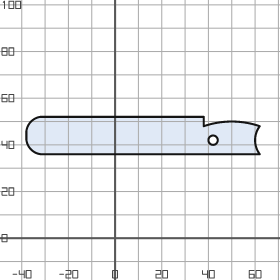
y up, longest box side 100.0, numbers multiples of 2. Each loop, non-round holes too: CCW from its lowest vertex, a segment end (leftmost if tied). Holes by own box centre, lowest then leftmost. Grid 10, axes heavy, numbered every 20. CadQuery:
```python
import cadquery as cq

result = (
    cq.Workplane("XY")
    .moveTo(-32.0, 36.0)
    .lineTo(62.0, 36.0)
    .threePointArc((60.0, 42.0), (62.0, 48.0))
    .threePointArc((50.0, 50.0), (38.0, 48.0))
    .lineTo(38.0, 52.0)
    .lineTo(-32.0, 52.0)
    .threePointArc((-36.0, 50.0), (-38.0, 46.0))
    .lineTo(-38.0, 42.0)
    .threePointArc((-36.0, 38.0), (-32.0, 36.0))
    .close()
    .moveTo(42.0, 42.0)
    .circle(2.0)
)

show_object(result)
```